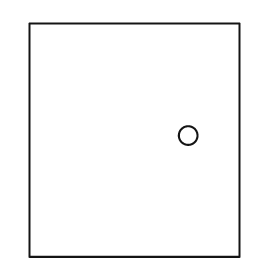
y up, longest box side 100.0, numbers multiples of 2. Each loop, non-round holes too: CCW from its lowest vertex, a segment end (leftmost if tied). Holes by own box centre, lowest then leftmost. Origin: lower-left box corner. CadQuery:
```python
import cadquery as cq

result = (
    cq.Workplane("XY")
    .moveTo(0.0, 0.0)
    .lineTo(90.0, 0.0)
    .lineTo(90.0, 100.0)
    .lineTo(0.0, 100.0)
    .close()
    .moveTo(68.0, 52.0)
    .circle(4.0)
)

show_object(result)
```